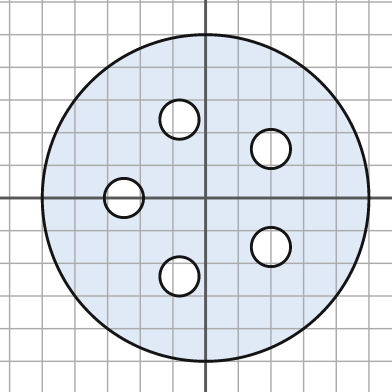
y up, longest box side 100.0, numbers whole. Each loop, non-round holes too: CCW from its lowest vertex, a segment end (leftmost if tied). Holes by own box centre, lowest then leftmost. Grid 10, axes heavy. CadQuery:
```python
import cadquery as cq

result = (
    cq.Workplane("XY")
    .moveTo(0.0, 0.0)
    .circle(50.0)
    .moveTo(-8.0, -24.0)
    .circle(6.0)
    .moveTo(20.0, -15.0)
    .circle(6.0)
    .moveTo(-25.0, 0.0)
    .circle(6.0)
    .moveTo(20.0, 15.0)
    .circle(6.0)
    .moveTo(-8.0, 24.0)
    .circle(6.0)
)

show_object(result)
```